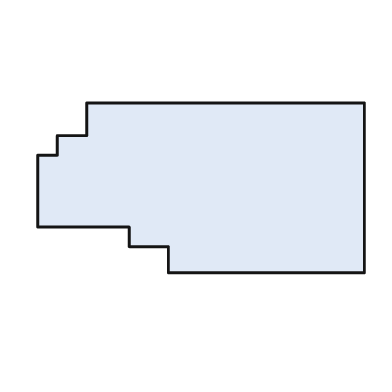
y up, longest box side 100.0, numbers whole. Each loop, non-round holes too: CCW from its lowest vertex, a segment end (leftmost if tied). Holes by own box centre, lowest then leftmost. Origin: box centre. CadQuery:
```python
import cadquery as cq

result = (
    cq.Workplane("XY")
    .moveTo(-10.0, -26.0)
    .lineTo(50.0, -26.0)
    .lineTo(50.0, 26.0)
    .lineTo(-35.0, 26.0)
    .lineTo(-35.0, 16.0)
    .lineTo(-44.0, 16.0)
    .lineTo(-44.0, 10.0)
    .lineTo(-50.0, 10.0)
    .lineTo(-50.0, -12.0)
    .lineTo(-22.0, -12.0)
    .lineTo(-22.0, -18.0)
    .lineTo(-10.0, -18.0)
    .close()
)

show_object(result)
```